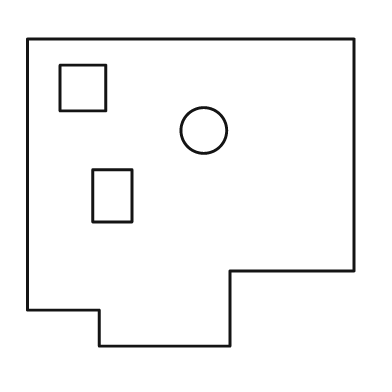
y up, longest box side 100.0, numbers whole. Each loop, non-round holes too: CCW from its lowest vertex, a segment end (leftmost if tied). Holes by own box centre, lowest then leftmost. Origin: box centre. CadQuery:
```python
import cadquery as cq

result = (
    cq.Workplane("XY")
    .moveTo(-28.0, -47.0)
    .lineTo(12.0, -47.0)
    .lineTo(12.0, -24.0)
    .lineTo(50.0, -24.0)
    .lineTo(50.0, 47.0)
    .lineTo(-50.0, 47.0)
    .lineTo(-50.0, -36.0)
    .lineTo(-28.0, -36.0)
    .close()
    .moveTo(-30.0, -9.0)
    .lineTo(-18.0, -9.0)
    .lineTo(-18.0, 7.0)
    .lineTo(-30.0, 7.0)
    .close()
    .moveTo(4.0, 19.0)
    .circle(7.0)
    .moveTo(-40.0, 25.0)
    .lineTo(-26.0, 25.0)
    .lineTo(-26.0, 39.0)
    .lineTo(-40.0, 39.0)
    .close()
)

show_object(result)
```